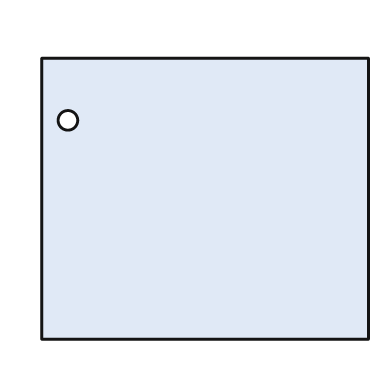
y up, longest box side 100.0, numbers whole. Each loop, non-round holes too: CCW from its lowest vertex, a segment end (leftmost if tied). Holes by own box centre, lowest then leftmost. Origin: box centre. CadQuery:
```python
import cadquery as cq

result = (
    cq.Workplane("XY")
    .moveTo(-50.0, -43.0)
    .lineTo(50.0, -43.0)
    .lineTo(50.0, 43.0)
    .lineTo(-50.0, 43.0)
    .close()
    .moveTo(-42.0, 24.0)
    .circle(3.0)
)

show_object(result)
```